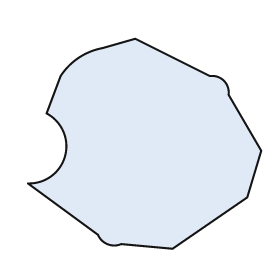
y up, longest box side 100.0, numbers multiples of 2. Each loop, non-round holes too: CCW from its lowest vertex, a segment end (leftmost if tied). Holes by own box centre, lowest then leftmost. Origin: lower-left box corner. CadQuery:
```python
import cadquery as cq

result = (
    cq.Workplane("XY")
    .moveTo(62.0, 0.0)
    .lineTo(94.0, 22.0)
    .lineTo(100.0, 42.0)
    .lineTo(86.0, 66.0)
    .threePointArc((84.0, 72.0), (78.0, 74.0))
    .lineTo(46.0, 90.0)
    .lineTo(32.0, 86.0)
    .threePointArc((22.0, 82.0), (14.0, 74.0))
    .lineTo(8.0, 58.0)
    .threePointArc((16.0, 40.0), (0.0, 28.0))
    .lineTo(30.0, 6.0)
    .threePointArc((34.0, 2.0), (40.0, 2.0))
    .close()
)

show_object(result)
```